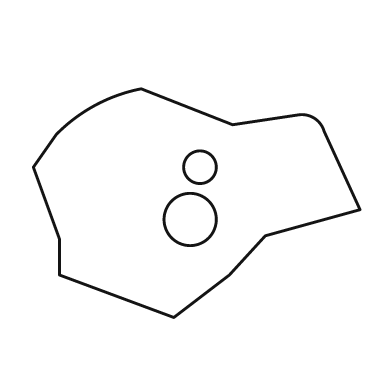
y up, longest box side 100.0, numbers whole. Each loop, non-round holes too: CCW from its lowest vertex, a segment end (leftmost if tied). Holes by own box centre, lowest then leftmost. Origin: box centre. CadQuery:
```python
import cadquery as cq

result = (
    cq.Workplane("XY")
    .moveTo(-7.0, -35.0)
    .lineTo(10.0, -22.0)
    .lineTo(21.0, -10.0)
    .lineTo(50.0, -2.0)
    .lineTo(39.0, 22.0)
    .threePointArc((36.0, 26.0), (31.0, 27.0))
    .lineTo(11.0, 24.0)
    .lineTo(-17.0, 35.0)
    .threePointArc((-31.0, 30.0), (-43.0, 21.0))
    .lineTo(-50.0, 11.0)
    .lineTo(-42.0, -11.0)
    .lineTo(-42.0, -22.0)
    .close()
    .moveTo(-2.0, -5.0)
    .circle(8.0)
    .moveTo(1.0, 11.0)
    .circle(5.0)
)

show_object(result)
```